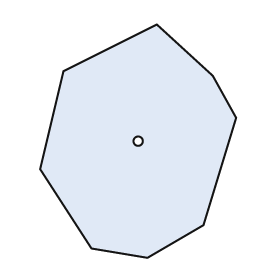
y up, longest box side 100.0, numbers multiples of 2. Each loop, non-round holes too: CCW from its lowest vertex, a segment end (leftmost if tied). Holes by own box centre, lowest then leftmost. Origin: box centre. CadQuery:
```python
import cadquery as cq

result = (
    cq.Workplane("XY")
    .moveTo(4.0, -50.0)
    .lineTo(28.0, -36.0)
    .lineTo(42.0, 10.0)
    .lineTo(32.0, 28.0)
    .lineTo(8.0, 50.0)
    .lineTo(-32.0, 30.0)
    .lineTo(-42.0, -12.0)
    .lineTo(-20.0, -46.0)
    .close()
    .moveTo(0.0, 0.0)
    .circle(2.0)
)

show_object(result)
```